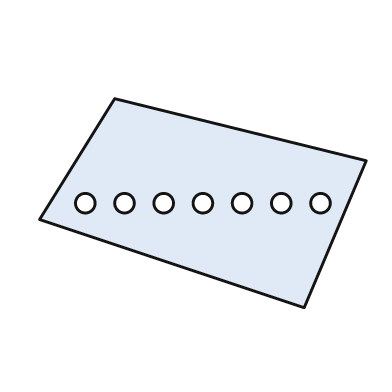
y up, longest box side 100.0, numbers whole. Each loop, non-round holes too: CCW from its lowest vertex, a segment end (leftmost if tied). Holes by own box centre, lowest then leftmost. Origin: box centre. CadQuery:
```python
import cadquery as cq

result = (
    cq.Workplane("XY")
    .moveTo(31.0, -32.0)
    .lineTo(50.0, 13.0)
    .lineTo(-27.0, 32.0)
    .lineTo(-50.0, -5.0)
    .close()
    .moveTo(-36.0, 0.0)
    .circle(3.0)
    .moveTo(-24.0, 0.0)
    .circle(3.0)
    .moveTo(-12.0, 0.0)
    .circle(3.0)
    .moveTo(0.0, 0.0)
    .circle(3.0)
    .moveTo(12.0, 0.0)
    .circle(3.0)
    .moveTo(24.0, 0.0)
    .circle(3.0)
    .moveTo(36.0, 0.0)
    .circle(3.0)
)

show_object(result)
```